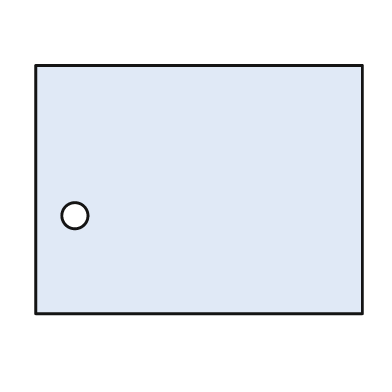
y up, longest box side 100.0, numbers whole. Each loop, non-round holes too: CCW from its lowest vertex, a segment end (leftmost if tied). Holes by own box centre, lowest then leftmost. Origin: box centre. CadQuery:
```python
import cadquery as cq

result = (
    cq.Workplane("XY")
    .moveTo(-50.0, -38.0)
    .lineTo(50.0, -38.0)
    .lineTo(50.0, 38.0)
    .lineTo(-50.0, 38.0)
    .close()
    .moveTo(-38.0, -8.0)
    .circle(4.0)
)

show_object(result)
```